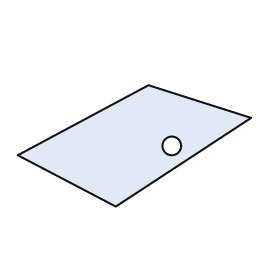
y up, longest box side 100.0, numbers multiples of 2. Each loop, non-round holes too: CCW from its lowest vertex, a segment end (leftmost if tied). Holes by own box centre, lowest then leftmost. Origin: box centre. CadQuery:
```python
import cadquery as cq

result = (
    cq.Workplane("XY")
    .moveTo(-8.0, -26.0)
    .lineTo(50.0, 12.0)
    .lineTo(6.0, 26.0)
    .lineTo(-50.0, -4.0)
    .close()
    .moveTo(16.0, 0.0)
    .circle(4.0)
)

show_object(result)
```